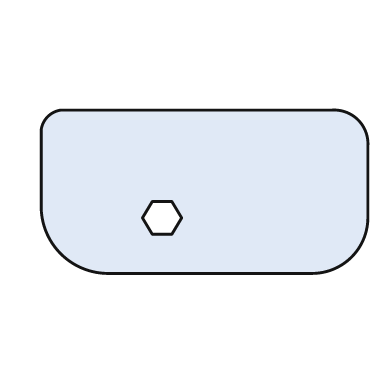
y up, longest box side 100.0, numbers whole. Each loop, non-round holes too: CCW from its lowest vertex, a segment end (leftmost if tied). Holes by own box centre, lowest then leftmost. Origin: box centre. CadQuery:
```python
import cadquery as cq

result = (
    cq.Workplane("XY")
    .moveTo(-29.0, -25.0)
    .lineTo(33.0, -25.0)
    .threePointArc((45.0, -20.0), (50.0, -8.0))
    .lineTo(50.0, 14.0)
    .threePointArc((47.0, 22.0), (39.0, 25.0))
    .lineTo(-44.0, 25.0)
    .threePointArc((-48.0, 23.0), (-50.0, 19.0))
    .lineTo(-50.0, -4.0)
    .threePointArc((-44.0, -19.0), (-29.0, -25.0))
    .close()
    .moveTo(-16.0, -13.0)
    .lineTo(-10.0, -13.0)
    .lineTo(-7.0, -8.0)
    .lineTo(-10.0, -3.0)
    .lineTo(-16.0, -3.0)
    .lineTo(-19.0, -8.0)
    .close()
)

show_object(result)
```